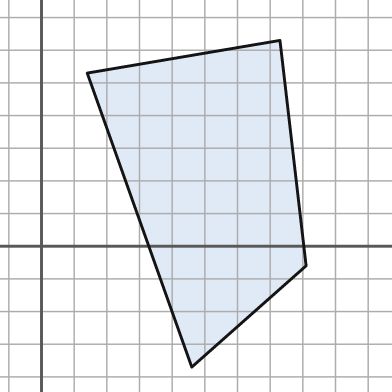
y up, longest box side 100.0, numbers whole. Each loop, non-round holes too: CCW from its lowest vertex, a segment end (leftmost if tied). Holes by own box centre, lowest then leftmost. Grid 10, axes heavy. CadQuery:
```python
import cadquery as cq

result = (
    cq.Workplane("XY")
    .moveTo(46.0, -37.0)
    .lineTo(81.0, -6.0)
    .lineTo(73.0, 63.0)
    .lineTo(14.0, 53.0)
    .close()
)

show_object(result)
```